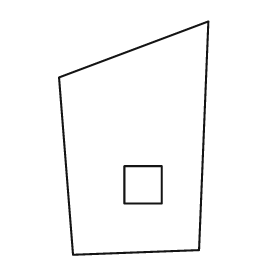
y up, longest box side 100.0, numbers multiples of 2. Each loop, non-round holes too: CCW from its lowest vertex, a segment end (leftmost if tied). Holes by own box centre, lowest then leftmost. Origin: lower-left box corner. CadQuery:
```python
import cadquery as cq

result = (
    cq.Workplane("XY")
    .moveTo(6.0, 0.0)
    .lineTo(60.0, 2.0)
    .lineTo(64.0, 100.0)
    .lineTo(0.0, 76.0)
    .close()
    .moveTo(28.0, 22.0)
    .lineTo(44.0, 22.0)
    .lineTo(44.0, 38.0)
    .lineTo(28.0, 38.0)
    .close()
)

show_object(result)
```